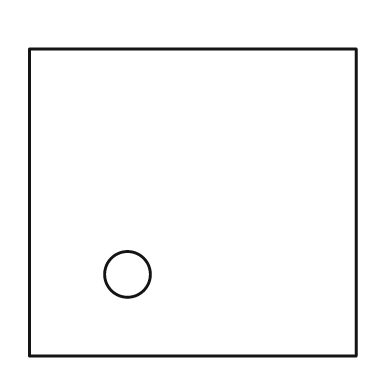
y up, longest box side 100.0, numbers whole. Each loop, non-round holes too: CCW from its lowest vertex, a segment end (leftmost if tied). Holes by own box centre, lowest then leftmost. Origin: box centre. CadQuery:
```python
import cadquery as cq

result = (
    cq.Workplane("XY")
    .moveTo(-50.0, -47.0)
    .lineTo(50.0, -47.0)
    .lineTo(50.0, 47.0)
    .lineTo(-50.0, 47.0)
    .close()
    .moveTo(-20.0, -22.0)
    .circle(7.0)
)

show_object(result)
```